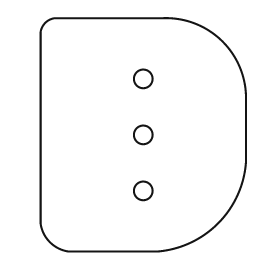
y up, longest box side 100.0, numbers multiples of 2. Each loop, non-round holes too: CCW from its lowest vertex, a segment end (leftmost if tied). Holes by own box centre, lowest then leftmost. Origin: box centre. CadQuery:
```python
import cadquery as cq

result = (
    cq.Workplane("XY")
    .moveTo(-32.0, -50.0)
    .lineTo(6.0, -50.0)
    .threePointArc((32.0, -38.0), (44.0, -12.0))
    .lineTo(44.0, 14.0)
    .threePointArc((34.0, 40.0), (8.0, 50.0))
    .lineTo(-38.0, 50.0)
    .threePointArc((-42.0, 48.0), (-44.0, 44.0))
    .lineTo(-44.0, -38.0)
    .threePointArc((-40.0, -46.0), (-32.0, -50.0))
    .close()
    .moveTo(0.0, -24.0)
    .circle(4.0)
    .moveTo(0.0, 0.0)
    .circle(4.0)
    .moveTo(0.0, 24.0)
    .circle(4.0)
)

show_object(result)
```